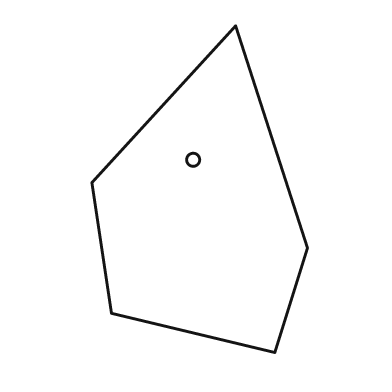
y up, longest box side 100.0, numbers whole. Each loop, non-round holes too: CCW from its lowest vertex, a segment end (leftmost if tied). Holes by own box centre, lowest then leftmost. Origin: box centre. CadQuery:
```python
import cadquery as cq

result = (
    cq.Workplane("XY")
    .moveTo(23.0, -50.0)
    .lineTo(33.0, -18.0)
    .lineTo(11.0, 50.0)
    .lineTo(-33.0, 2.0)
    .lineTo(-27.0, -38.0)
    .close()
    .moveTo(-2.0, 9.0)
    .circle(2.0)
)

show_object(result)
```